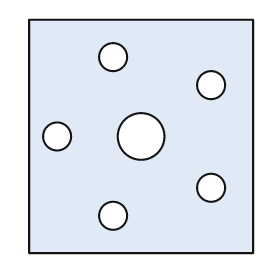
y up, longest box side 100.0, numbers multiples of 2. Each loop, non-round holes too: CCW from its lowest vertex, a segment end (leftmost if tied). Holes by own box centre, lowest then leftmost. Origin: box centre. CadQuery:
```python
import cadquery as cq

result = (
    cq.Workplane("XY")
    .moveTo(-48.0, -50.0)
    .lineTo(48.0, -50.0)
    .lineTo(48.0, 50.0)
    .lineTo(-48.0, 50.0)
    .close()
    .moveTo(-12.0, -34.0)
    .circle(6.0)
    .moveTo(30.0, -22.0)
    .circle(6.0)
    .moveTo(-36.0, 0.0)
    .circle(6.0)
    .moveTo(0.0, 0.0)
    .circle(10.0)
    .moveTo(30.0, 22.0)
    .circle(6.0)
    .moveTo(-12.0, 34.0)
    .circle(6.0)
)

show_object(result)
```